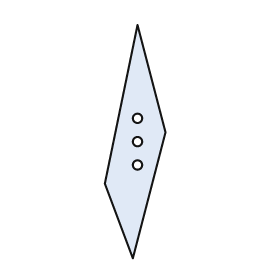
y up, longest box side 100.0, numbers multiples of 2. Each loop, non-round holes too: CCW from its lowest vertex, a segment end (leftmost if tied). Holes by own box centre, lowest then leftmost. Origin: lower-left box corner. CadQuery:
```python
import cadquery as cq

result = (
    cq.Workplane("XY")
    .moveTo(12.0, 0.0)
    .lineTo(26.0, 54.0)
    .lineTo(14.0, 100.0)
    .lineTo(0.0, 32.0)
    .close()
    .moveTo(14.0, 40.0)
    .circle(2.0)
    .moveTo(14.0, 50.0)
    .circle(2.0)
    .moveTo(14.0, 60.0)
    .circle(2.0)
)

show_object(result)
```